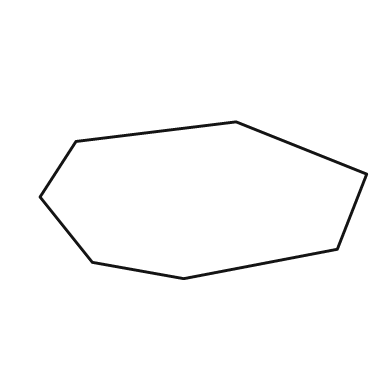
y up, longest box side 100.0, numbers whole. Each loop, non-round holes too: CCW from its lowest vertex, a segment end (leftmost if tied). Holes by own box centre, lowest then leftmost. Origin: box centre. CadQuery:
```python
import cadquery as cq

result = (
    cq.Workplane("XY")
    .moveTo(-6.0, -24.0)
    .lineTo(41.0, -15.0)
    .lineTo(50.0, 8.0)
    .lineTo(10.0, 24.0)
    .lineTo(-39.0, 18.0)
    .lineTo(-50.0, 1.0)
    .lineTo(-34.0, -19.0)
    .close()
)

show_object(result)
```